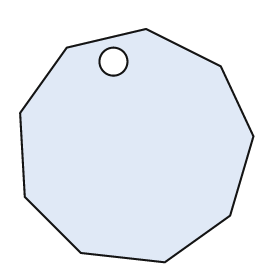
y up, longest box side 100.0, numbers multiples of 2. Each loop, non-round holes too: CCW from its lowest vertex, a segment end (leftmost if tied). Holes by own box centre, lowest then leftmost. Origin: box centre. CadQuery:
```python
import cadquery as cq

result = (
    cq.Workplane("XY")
    .moveTo(12.0, -50.0)
    .lineTo(40.0, -30.0)
    .lineTo(50.0, 4.0)
    .lineTo(36.0, 34.0)
    .lineTo(4.0, 50.0)
    .lineTo(-30.0, 42.0)
    .lineTo(-50.0, 14.0)
    .lineTo(-48.0, -22.0)
    .lineTo(-24.0, -46.0)
    .close()
    .moveTo(-10.0, 36.0)
    .circle(6.0)
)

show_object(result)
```